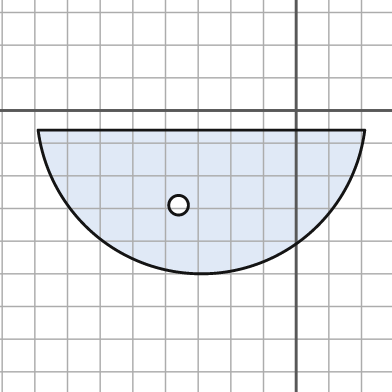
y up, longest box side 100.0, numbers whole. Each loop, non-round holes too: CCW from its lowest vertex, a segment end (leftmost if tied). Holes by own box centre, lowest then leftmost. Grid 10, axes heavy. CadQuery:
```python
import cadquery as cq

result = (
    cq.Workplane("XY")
    .moveTo(-79.0, -6.0)
    .threePointArc((-29.0, -50.0), (21.0, -6.0))
    .close()
    .moveTo(-36.0, -29.0)
    .circle(3.0)
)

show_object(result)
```